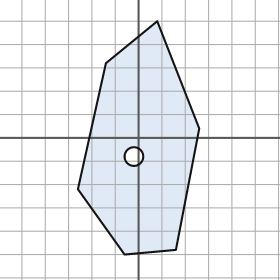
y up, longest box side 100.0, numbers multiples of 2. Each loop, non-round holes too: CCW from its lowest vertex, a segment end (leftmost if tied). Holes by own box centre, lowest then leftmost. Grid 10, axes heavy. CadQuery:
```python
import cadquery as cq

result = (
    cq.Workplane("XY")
    .moveTo(-6.0, -50.0)
    .lineTo(16.0, -48.0)
    .lineTo(26.0, 4.0)
    .lineTo(8.0, 50.0)
    .lineTo(-14.0, 32.0)
    .lineTo(-26.0, -22.0)
    .close()
    .moveTo(-2.0, -8.0)
    .circle(4.0)
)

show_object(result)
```